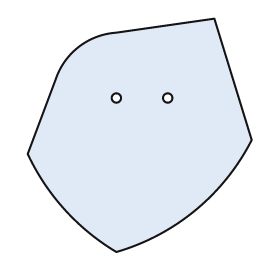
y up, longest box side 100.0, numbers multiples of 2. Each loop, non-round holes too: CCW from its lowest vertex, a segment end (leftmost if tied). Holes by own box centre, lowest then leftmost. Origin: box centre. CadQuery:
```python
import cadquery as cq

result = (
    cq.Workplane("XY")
    .moveTo(-10.0, -50.0)
    .threePointArc((24.0, -32.0), (48.0, -2.0))
    .lineTo(32.0, 50.0)
    .lineTo(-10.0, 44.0)
    .threePointArc((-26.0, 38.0), (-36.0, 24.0))
    .lineTo(-48.0, -8.0)
    .threePointArc((-32.0, -32.0), (-10.0, -50.0))
    .close()
    .moveTo(-10.0, 16.0)
    .circle(2.0)
    .moveTo(12.0, 16.0)
    .circle(2.0)
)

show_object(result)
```